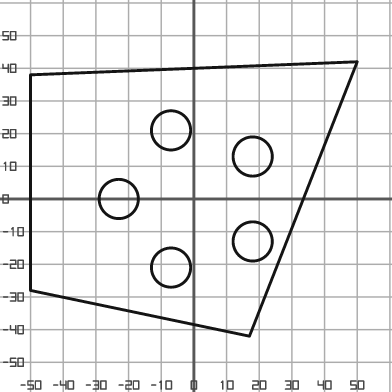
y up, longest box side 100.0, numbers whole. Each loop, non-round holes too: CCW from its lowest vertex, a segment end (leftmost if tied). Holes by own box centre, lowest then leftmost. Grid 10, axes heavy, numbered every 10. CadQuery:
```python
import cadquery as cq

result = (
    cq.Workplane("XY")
    .moveTo(17.0, -42.0)
    .lineTo(50.0, 42.0)
    .lineTo(-50.0, 38.0)
    .lineTo(-50.0, -28.0)
    .close()
    .moveTo(-7.0, -21.0)
    .circle(6.0)
    .moveTo(18.0, -13.0)
    .circle(6.0)
    .moveTo(-23.0, 0.0)
    .circle(6.0)
    .moveTo(18.0, 13.0)
    .circle(6.0)
    .moveTo(-7.0, 21.0)
    .circle(6.0)
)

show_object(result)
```